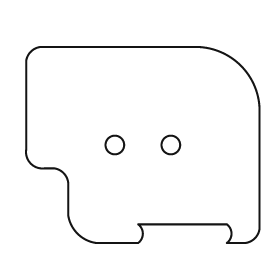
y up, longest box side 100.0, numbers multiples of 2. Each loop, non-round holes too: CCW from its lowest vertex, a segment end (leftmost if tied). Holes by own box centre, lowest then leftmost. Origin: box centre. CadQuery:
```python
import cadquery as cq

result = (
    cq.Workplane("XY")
    .moveTo(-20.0, -42.0)
    .lineTo(-2.0, -42.0)
    .threePointArc((0.0, -38.0), (-2.0, -34.0))
    .lineTo(36.0, -34.0)
    .threePointArc((38.0, -38.0), (36.0, -42.0))
    .lineTo(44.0, -42.0)
    .threePointArc((48.0, -40.0), (50.0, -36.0))
    .lineTo(50.0, 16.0)
    .threePointArc((42.0, 34.0), (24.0, 42.0))
    .lineTo(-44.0, 42.0)
    .threePointArc((-48.0, 40.0), (-50.0, 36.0))
    .lineTo(-50.0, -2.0)
    .threePointArc((-48.0, -8.0), (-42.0, -10.0))
    .lineTo(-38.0, -10.0)
    .threePointArc((-34.0, -12.0), (-32.0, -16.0))
    .lineTo(-32.0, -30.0)
    .threePointArc((-28.0, -38.0), (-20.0, -42.0))
    .close()
    .moveTo(-12.0, 0.0)
    .circle(4.0)
    .moveTo(12.0, 0.0)
    .circle(4.0)
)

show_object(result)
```